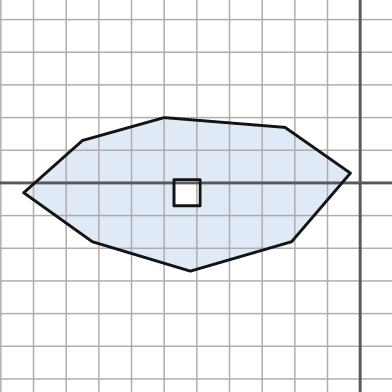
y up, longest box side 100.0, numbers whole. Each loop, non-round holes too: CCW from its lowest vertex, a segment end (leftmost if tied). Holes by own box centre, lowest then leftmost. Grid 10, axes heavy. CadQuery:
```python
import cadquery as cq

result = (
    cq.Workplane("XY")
    .moveTo(-52.0, -27.0)
    .lineTo(-21.0, -18.0)
    .lineTo(-3.0, 3.0)
    .lineTo(-23.0, 17.0)
    .lineTo(-60.0, 20.0)
    .lineTo(-85.0, 13.0)
    .lineTo(-103.0, -3.0)
    .lineTo(-82.0, -18.0)
    .close()
    .moveTo(-57.0, -7.0)
    .lineTo(-49.0, -7.0)
    .lineTo(-49.0, 1.0)
    .lineTo(-57.0, 1.0)
    .close()
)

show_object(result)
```